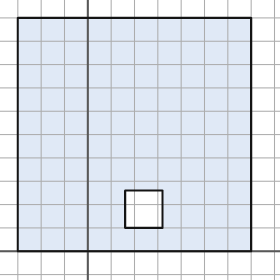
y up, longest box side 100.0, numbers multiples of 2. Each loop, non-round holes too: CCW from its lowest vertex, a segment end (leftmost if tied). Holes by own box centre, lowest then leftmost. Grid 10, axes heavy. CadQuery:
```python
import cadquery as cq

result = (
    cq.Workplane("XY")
    .moveTo(-30.0, 0.0)
    .lineTo(70.0, 0.0)
    .lineTo(70.0, 100.0)
    .lineTo(-30.0, 100.0)
    .close()
    .moveTo(16.0, 10.0)
    .lineTo(32.0, 10.0)
    .lineTo(32.0, 26.0)
    .lineTo(16.0, 26.0)
    .close()
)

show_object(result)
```